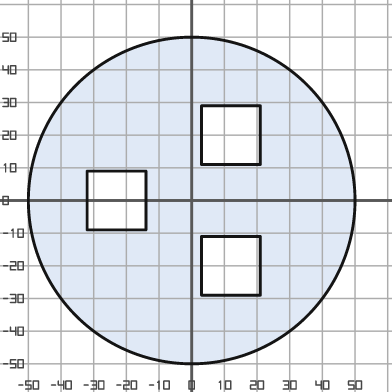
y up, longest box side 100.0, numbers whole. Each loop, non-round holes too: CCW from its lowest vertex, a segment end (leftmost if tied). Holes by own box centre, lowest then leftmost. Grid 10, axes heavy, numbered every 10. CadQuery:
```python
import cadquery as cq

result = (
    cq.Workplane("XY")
    .moveTo(0.0, 0.0)
    .circle(50.0)
    .moveTo(3.0, -29.0)
    .lineTo(21.0, -29.0)
    .lineTo(21.0, -11.0)
    .lineTo(3.0, -11.0)
    .close()
    .moveTo(-32.0, -9.0)
    .lineTo(-14.0, -9.0)
    .lineTo(-14.0, 9.0)
    .lineTo(-32.0, 9.0)
    .close()
    .moveTo(3.0, 11.0)
    .lineTo(21.0, 11.0)
    .lineTo(21.0, 29.0)
    .lineTo(3.0, 29.0)
    .close()
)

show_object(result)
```